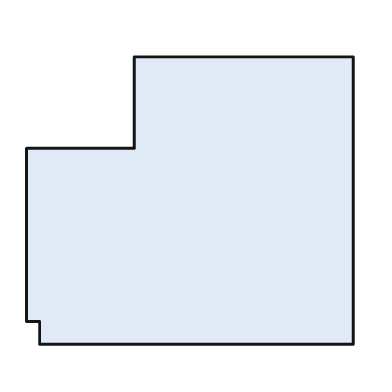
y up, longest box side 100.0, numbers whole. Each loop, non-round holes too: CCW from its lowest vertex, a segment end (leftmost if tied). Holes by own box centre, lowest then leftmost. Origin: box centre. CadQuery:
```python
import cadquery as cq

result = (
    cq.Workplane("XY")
    .moveTo(-46.0, -44.0)
    .lineTo(50.0, -44.0)
    .lineTo(50.0, 44.0)
    .lineTo(-17.0, 44.0)
    .lineTo(-17.0, 16.0)
    .lineTo(-50.0, 16.0)
    .lineTo(-50.0, -37.0)
    .lineTo(-46.0, -37.0)
    .close()
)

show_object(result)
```